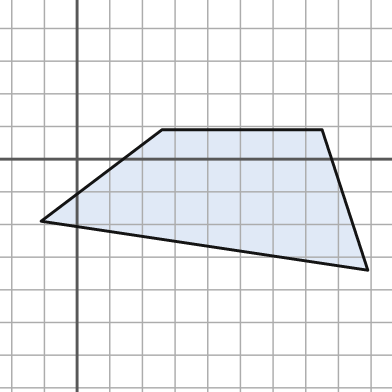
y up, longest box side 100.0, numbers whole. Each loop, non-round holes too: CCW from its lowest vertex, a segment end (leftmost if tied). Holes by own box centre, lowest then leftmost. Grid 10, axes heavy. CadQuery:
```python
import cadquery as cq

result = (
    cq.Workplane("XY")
    .moveTo(89.0, -34.0)
    .lineTo(75.0, 9.0)
    .lineTo(26.0, 9.0)
    .lineTo(-11.0, -19.0)
    .close()
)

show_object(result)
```